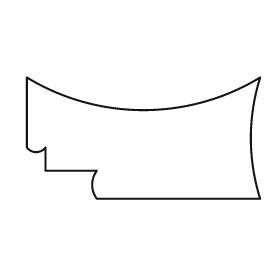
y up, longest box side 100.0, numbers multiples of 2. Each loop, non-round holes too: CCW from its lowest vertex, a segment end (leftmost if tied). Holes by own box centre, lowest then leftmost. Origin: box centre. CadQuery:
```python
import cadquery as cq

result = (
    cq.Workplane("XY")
    .moveTo(-20.0, -26.0)
    .lineTo(50.0, -26.0)
    .threePointArc((46.0, 0.0), (50.0, 26.0))
    .threePointArc((0.0, 12.0), (-50.0, 26.0))
    .lineTo(-50.0, -4.0)
    .threePointArc((-46.0, -6.0), (-42.0, -4.0))
    .lineTo(-42.0, -14.0)
    .lineTo(-20.0, -14.0)
    .threePointArc((-22.0, -20.0), (-20.0, -26.0))
    .close()
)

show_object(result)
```